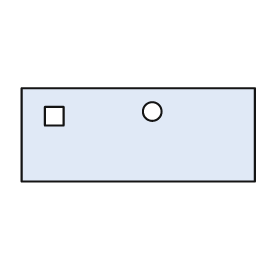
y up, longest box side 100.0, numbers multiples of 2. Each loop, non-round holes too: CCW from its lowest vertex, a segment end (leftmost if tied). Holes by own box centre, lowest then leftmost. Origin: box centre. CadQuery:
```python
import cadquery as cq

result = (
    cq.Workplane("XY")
    .moveTo(-50.0, -20.0)
    .lineTo(50.0, -20.0)
    .lineTo(50.0, 20.0)
    .lineTo(-50.0, 20.0)
    .close()
    .moveTo(-40.0, 4.0)
    .lineTo(-32.0, 4.0)
    .lineTo(-32.0, 12.0)
    .lineTo(-40.0, 12.0)
    .close()
    .moveTo(6.0, 10.0)
    .circle(4.0)
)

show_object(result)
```